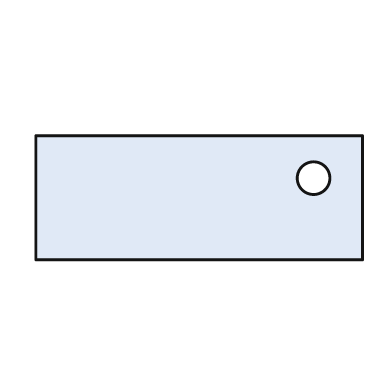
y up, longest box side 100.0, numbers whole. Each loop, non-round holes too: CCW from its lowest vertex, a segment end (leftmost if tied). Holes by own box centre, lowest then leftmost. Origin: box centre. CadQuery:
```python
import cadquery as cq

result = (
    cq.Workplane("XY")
    .moveTo(-50.0, -19.0)
    .lineTo(50.0, -19.0)
    .lineTo(50.0, 19.0)
    .lineTo(-50.0, 19.0)
    .close()
    .moveTo(35.0, 6.0)
    .circle(5.0)
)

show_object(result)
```